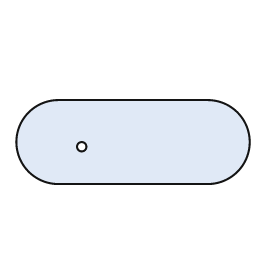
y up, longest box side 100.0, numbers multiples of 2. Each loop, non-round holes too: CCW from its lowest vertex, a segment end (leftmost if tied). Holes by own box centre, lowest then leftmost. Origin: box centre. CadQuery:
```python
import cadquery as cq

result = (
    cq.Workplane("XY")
    .moveTo(-32.0, -18.0)
    .lineTo(32.0, -18.0)
    .threePointArc((50.0, 0.0), (32.0, 18.0))
    .lineTo(-32.0, 18.0)
    .threePointArc((-50.0, 0.0), (-32.0, -18.0))
    .close()
    .moveTo(-22.0, -2.0)
    .circle(2.0)
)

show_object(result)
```